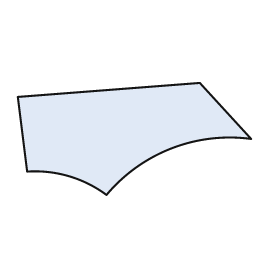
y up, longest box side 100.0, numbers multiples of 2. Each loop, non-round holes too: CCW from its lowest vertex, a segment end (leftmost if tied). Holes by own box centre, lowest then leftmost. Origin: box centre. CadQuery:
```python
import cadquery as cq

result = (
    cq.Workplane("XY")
    .moveTo(-12.0, -24.0)
    .threePointArc((16.0, -4.0), (50.0, 0.0))
    .lineTo(28.0, 24.0)
    .lineTo(-50.0, 18.0)
    .lineTo(-46.0, -14.0)
    .threePointArc((-28.0, -16.0), (-12.0, -24.0))
    .close()
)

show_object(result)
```